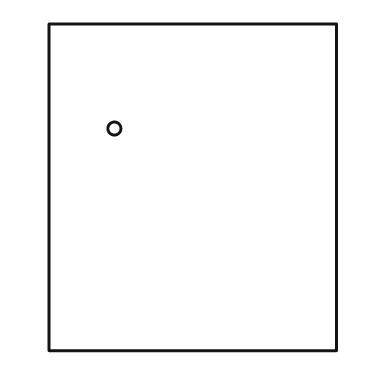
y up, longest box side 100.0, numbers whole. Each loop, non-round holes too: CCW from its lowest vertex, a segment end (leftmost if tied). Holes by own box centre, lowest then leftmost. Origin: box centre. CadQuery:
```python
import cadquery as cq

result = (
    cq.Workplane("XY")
    .moveTo(-44.0, -50.0)
    .lineTo(44.0, -50.0)
    .lineTo(44.0, 50.0)
    .lineTo(-44.0, 50.0)
    .close()
    .moveTo(-24.0, 18.0)
    .circle(2.0)
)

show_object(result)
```